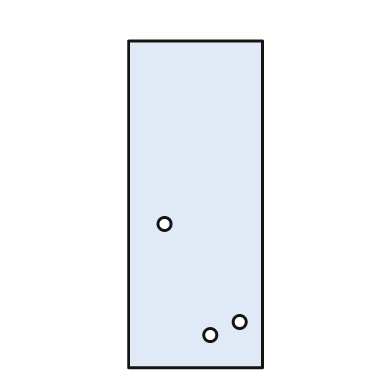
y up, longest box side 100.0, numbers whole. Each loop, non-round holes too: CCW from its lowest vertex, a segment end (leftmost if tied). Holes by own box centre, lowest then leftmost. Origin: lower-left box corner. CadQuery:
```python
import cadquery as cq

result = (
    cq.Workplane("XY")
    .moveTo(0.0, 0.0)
    .lineTo(41.0, 0.0)
    .lineTo(41.0, 100.0)
    .lineTo(0.0, 100.0)
    .close()
    .moveTo(25.0, 10.0)
    .circle(2.0)
    .moveTo(34.0, 14.0)
    .circle(2.0)
    .moveTo(11.0, 44.0)
    .circle(2.0)
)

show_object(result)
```